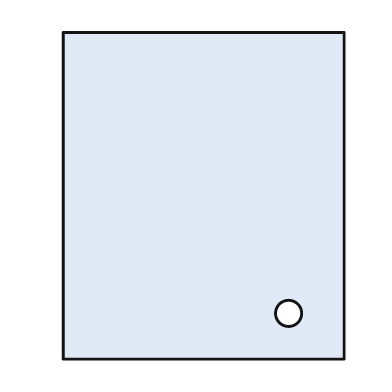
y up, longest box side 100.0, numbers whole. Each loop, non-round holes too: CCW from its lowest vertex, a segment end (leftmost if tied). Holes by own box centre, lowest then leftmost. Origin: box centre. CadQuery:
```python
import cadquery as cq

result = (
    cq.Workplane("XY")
    .moveTo(-43.0, -50.0)
    .lineTo(43.0, -50.0)
    .lineTo(43.0, 50.0)
    .lineTo(-43.0, 50.0)
    .close()
    .moveTo(26.0, -36.0)
    .circle(4.0)
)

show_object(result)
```